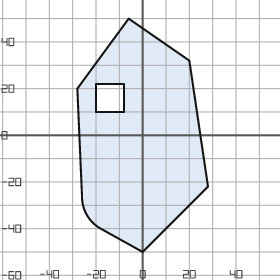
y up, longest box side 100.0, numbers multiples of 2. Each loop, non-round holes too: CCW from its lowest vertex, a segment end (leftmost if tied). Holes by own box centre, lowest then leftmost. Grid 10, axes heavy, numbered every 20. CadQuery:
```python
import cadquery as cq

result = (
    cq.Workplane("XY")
    .moveTo(0.0, -50.0)
    .lineTo(28.0, -22.0)
    .lineTo(20.0, 32.0)
    .lineTo(-6.0, 50.0)
    .lineTo(-28.0, 20.0)
    .lineTo(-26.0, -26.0)
    .threePointArc((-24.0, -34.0), (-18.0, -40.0))
    .close()
    .moveTo(-20.0, 10.0)
    .lineTo(-8.0, 10.0)
    .lineTo(-8.0, 22.0)
    .lineTo(-20.0, 22.0)
    .close()
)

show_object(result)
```